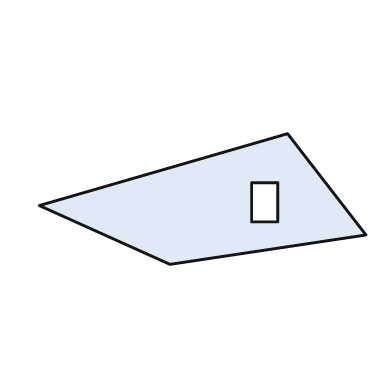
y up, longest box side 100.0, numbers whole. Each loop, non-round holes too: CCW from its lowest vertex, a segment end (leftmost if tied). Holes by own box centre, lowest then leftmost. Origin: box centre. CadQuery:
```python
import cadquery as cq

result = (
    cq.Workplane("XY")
    .moveTo(-10.0, -20.0)
    .lineTo(50.0, -11.0)
    .lineTo(26.0, 20.0)
    .lineTo(-50.0, -2.0)
    .close()
    .moveTo(15.0, -7.0)
    .lineTo(23.0, -7.0)
    .lineTo(23.0, 5.0)
    .lineTo(15.0, 5.0)
    .close()
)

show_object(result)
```